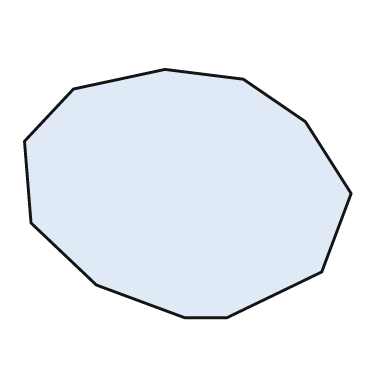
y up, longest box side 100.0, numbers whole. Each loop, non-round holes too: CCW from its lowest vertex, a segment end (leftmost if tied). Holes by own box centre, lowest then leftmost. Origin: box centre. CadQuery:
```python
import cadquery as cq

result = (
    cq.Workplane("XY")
    .moveTo(-1.0, -38.0)
    .lineTo(12.0, -38.0)
    .lineTo(41.0, -24.0)
    .lineTo(50.0, 0.0)
    .lineTo(36.0, 22.0)
    .lineTo(17.0, 35.0)
    .lineTo(-7.0, 38.0)
    .lineTo(-35.0, 32.0)
    .lineTo(-50.0, 16.0)
    .lineTo(-48.0, -9.0)
    .lineTo(-28.0, -28.0)
    .close()
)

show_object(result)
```